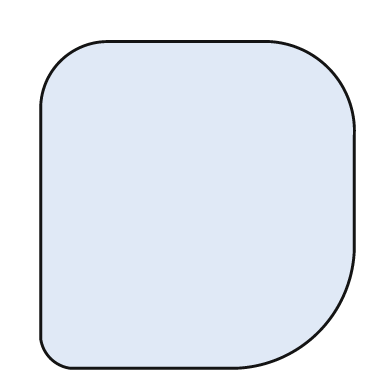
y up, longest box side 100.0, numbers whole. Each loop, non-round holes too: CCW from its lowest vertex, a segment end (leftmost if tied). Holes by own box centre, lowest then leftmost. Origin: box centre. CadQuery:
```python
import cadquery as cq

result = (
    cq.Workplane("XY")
    .moveTo(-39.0, -50.0)
    .lineTo(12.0, -50.0)
    .threePointArc((37.0, -39.0), (48.0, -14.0))
    .lineTo(48.0, 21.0)
    .threePointArc((40.0, 42.0), (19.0, 50.0))
    .lineTo(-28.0, 50.0)
    .threePointArc((-42.0, 44.0), (-48.0, 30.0))
    .lineTo(-48.0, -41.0)
    .threePointArc((-45.0, -47.0), (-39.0, -50.0))
    .close()
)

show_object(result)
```